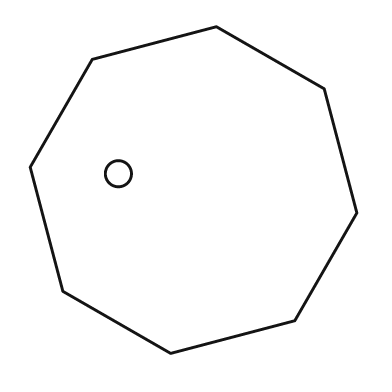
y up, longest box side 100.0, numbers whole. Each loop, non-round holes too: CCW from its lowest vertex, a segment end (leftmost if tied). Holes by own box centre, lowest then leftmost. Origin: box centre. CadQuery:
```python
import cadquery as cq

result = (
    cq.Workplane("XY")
    .moveTo(-7.0, -50.0)
    .lineTo(31.0, -40.0)
    .lineTo(50.0, -7.0)
    .lineTo(40.0, 31.0)
    .lineTo(7.0, 50.0)
    .lineTo(-31.0, 40.0)
    .lineTo(-50.0, 7.0)
    .lineTo(-40.0, -31.0)
    .close()
    .moveTo(-23.0, 5.0)
    .circle(4.0)
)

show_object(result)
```